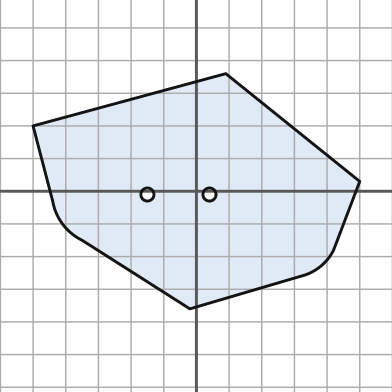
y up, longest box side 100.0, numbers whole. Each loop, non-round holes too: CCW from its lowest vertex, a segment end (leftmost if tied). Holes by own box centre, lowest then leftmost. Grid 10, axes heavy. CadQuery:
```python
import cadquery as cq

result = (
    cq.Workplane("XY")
    .moveTo(-2.0, -36.0)
    .lineTo(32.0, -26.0)
    .threePointArc((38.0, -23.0), (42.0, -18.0))
    .lineTo(50.0, 3.0)
    .lineTo(9.0, 36.0)
    .lineTo(-50.0, 20.0)
    .lineTo(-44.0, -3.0)
    .threePointArc((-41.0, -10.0), (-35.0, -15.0))
    .close()
    .moveTo(-15.0, -1.0)
    .circle(2.0)
    .moveTo(4.0, -1.0)
    .circle(2.0)
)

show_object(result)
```